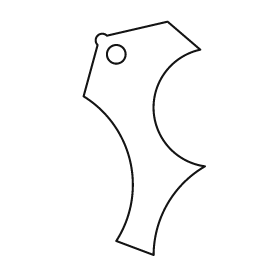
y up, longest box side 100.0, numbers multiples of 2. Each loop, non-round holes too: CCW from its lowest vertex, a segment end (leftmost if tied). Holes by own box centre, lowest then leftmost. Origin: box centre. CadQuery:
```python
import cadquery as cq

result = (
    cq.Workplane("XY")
    .moveTo(4.0, -50.0)
    .threePointArc((10.0, -28.0), (26.0, -12.0))
    .threePointArc((4.0, 12.0), (24.0, 38.0))
    .lineTo(10.0, 50.0)
    .lineTo(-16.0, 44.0)
    .threePointArc((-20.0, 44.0), (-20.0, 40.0))
    .lineTo(-26.0, 18.0)
    .threePointArc((-6.0, -10.0), (-12.0, -44.0))
    .close()
    .moveTo(-12.0, 36.0)
    .circle(4.0)
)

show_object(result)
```